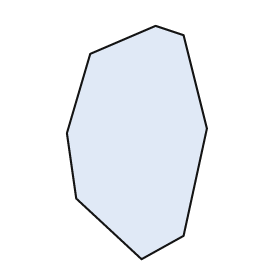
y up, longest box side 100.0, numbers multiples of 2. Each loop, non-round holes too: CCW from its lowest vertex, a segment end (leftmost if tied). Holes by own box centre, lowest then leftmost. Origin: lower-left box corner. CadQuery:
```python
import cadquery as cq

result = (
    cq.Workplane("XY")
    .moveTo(32.0, 0.0)
    .lineTo(50.0, 10.0)
    .lineTo(60.0, 56.0)
    .lineTo(50.0, 96.0)
    .lineTo(38.0, 100.0)
    .lineTo(10.0, 88.0)
    .lineTo(0.0, 54.0)
    .lineTo(4.0, 26.0)
    .close()
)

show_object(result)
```